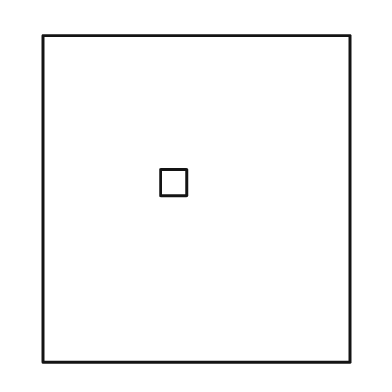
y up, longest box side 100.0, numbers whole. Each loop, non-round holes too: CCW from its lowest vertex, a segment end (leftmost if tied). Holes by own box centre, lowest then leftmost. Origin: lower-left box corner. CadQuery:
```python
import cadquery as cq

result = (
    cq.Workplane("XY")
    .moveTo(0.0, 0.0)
    .lineTo(94.0, 0.0)
    .lineTo(94.0, 100.0)
    .lineTo(0.0, 100.0)
    .close()
    .moveTo(36.0, 51.0)
    .lineTo(44.0, 51.0)
    .lineTo(44.0, 59.0)
    .lineTo(36.0, 59.0)
    .close()
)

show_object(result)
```